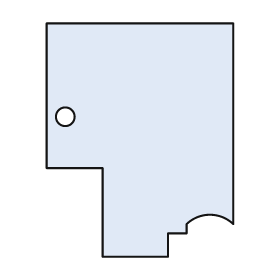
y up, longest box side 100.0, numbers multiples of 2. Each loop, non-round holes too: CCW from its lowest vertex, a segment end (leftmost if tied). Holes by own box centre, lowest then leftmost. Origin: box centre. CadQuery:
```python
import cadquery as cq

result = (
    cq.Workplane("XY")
    .moveTo(-16.0, -50.0)
    .lineTo(12.0, -50.0)
    .lineTo(12.0, -40.0)
    .lineTo(20.0, -40.0)
    .lineTo(20.0, -36.0)
    .threePointArc((30.0, -32.0), (40.0, -36.0))
    .lineTo(40.0, 50.0)
    .lineTo(-40.0, 50.0)
    .lineTo(-40.0, -12.0)
    .lineTo(-16.0, -12.0)
    .close()
    .moveTo(-32.0, 10.0)
    .circle(4.0)
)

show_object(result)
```